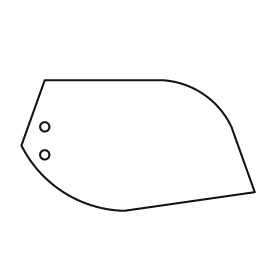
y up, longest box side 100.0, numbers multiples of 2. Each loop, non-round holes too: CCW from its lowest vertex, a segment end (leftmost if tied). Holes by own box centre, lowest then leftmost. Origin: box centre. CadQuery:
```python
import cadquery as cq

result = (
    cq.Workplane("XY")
    .moveTo(-6.0, -28.0)
    .lineTo(50.0, -20.0)
    .lineTo(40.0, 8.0)
    .threePointArc((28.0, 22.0), (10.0, 28.0))
    .lineTo(-40.0, 28.0)
    .lineTo(-50.0, 0.0)
    .threePointArc((-32.0, -20.0), (-6.0, -28.0))
    .close()
    .moveTo(-40.0, -4.0)
    .circle(2.0)
    .moveTo(-40.0, 8.0)
    .circle(2.0)
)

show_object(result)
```